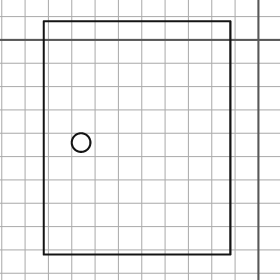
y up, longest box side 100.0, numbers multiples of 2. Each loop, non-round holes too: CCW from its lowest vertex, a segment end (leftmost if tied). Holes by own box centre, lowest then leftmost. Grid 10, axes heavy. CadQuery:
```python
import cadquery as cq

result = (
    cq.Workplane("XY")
    .moveTo(-92.0, -92.0)
    .lineTo(-12.0, -92.0)
    .lineTo(-12.0, 8.0)
    .lineTo(-92.0, 8.0)
    .close()
    .moveTo(-76.0, -44.0)
    .circle(4.0)
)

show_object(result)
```